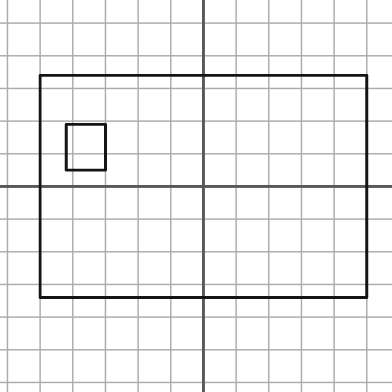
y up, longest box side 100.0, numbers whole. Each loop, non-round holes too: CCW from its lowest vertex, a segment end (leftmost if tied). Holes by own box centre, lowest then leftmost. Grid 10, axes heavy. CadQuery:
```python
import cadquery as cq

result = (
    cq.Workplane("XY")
    .moveTo(-50.0, -34.0)
    .lineTo(50.0, -34.0)
    .lineTo(50.0, 34.0)
    .lineTo(-50.0, 34.0)
    .close()
    .moveTo(-42.0, 5.0)
    .lineTo(-30.0, 5.0)
    .lineTo(-30.0, 19.0)
    .lineTo(-42.0, 19.0)
    .close()
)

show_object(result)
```